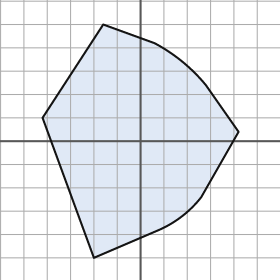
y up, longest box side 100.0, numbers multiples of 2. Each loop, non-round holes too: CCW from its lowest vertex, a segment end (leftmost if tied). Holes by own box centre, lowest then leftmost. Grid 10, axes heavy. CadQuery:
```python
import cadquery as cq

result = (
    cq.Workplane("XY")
    .moveTo(-20.0, -50.0)
    .lineTo(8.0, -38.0)
    .threePointArc((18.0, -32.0), (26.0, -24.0))
    .lineTo(42.0, 4.0)
    .lineTo(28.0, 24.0)
    .threePointArc((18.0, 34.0), (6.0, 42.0))
    .lineTo(-16.0, 50.0)
    .lineTo(-42.0, 10.0)
    .close()
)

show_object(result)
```